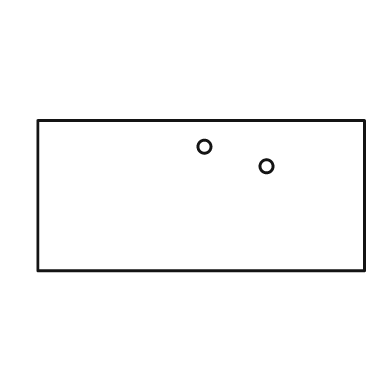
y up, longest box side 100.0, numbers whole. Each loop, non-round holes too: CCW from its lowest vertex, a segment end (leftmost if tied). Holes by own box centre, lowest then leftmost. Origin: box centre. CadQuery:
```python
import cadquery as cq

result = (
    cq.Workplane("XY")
    .moveTo(-50.0, -23.0)
    .lineTo(50.0, -23.0)
    .lineTo(50.0, 23.0)
    .lineTo(-50.0, 23.0)
    .close()
    .moveTo(20.0, 9.0)
    .circle(2.0)
    .moveTo(1.0, 15.0)
    .circle(2.0)
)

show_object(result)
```